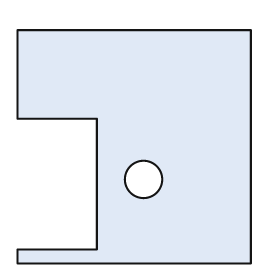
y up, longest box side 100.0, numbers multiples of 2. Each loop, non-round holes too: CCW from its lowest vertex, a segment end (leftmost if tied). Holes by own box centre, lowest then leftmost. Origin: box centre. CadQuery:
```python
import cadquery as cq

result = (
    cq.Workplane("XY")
    .moveTo(-50.0, -50.0)
    .lineTo(50.0, -50.0)
    .lineTo(50.0, 50.0)
    .lineTo(-50.0, 50.0)
    .lineTo(-50.0, 12.0)
    .lineTo(-16.0, 12.0)
    .lineTo(-16.0, -44.0)
    .lineTo(-50.0, -44.0)
    .close()
    .moveTo(4.0, -14.0)
    .circle(8.0)
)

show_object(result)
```